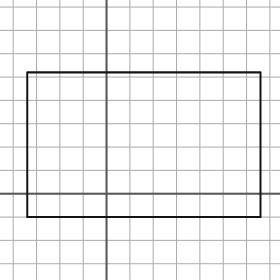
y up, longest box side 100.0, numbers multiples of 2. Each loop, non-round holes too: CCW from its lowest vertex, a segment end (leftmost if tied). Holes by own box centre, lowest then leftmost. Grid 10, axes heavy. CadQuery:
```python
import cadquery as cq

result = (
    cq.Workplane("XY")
    .moveTo(-34.0, -10.0)
    .lineTo(66.0, -10.0)
    .lineTo(66.0, 52.0)
    .lineTo(-34.0, 52.0)
    .close()
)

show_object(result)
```